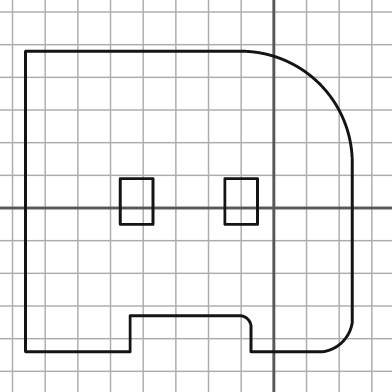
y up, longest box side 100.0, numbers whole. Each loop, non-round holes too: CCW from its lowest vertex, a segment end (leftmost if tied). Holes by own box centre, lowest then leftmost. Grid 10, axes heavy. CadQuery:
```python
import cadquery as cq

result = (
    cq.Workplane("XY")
    .moveTo(-76.0, -44.0)
    .lineTo(-44.0, -44.0)
    .lineTo(-44.0, -33.0)
    .lineTo(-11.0, -33.0)
    .threePointArc((-8.0, -34.0), (-7.0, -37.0))
    .lineTo(-7.0, -44.0)
    .lineTo(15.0, -44.0)
    .threePointArc((21.0, -41.0), (24.0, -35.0))
    .lineTo(24.0, 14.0)
    .threePointArc((14.0, 38.0), (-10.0, 48.0))
    .lineTo(-76.0, 48.0)
    .close()
    .moveTo(-47.0, -5.0)
    .lineTo(-37.0, -5.0)
    .lineTo(-37.0, 9.0)
    .lineTo(-47.0, 9.0)
    .close()
    .moveTo(-15.0, -5.0)
    .lineTo(-5.0, -5.0)
    .lineTo(-5.0, 9.0)
    .lineTo(-15.0, 9.0)
    .close()
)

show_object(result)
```